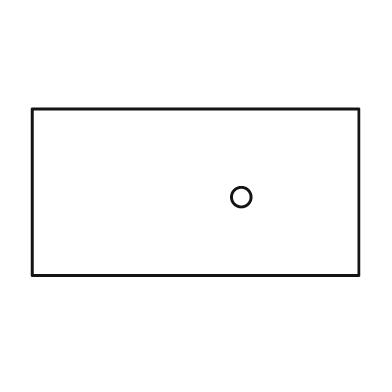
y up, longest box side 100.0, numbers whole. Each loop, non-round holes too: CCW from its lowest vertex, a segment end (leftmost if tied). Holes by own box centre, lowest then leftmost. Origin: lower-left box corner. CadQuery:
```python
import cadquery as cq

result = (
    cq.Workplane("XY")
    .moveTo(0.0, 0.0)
    .lineTo(100.0, 0.0)
    .lineTo(100.0, 51.0)
    .lineTo(0.0, 51.0)
    .close()
    .moveTo(64.0, 24.0)
    .circle(3.0)
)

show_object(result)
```